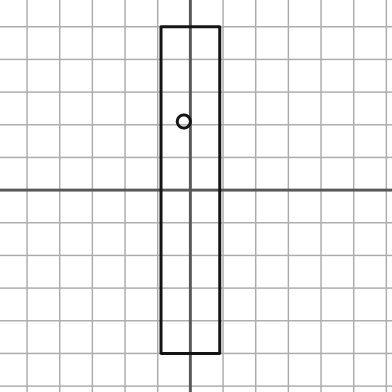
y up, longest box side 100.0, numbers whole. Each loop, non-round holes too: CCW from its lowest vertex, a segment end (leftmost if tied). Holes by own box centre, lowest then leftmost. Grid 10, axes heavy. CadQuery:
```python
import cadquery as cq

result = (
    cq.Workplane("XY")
    .moveTo(-9.0, -50.0)
    .lineTo(9.0, -50.0)
    .lineTo(9.0, 50.0)
    .lineTo(-9.0, 50.0)
    .close()
    .moveTo(-2.0, 21.0)
    .circle(2.0)
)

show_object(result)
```